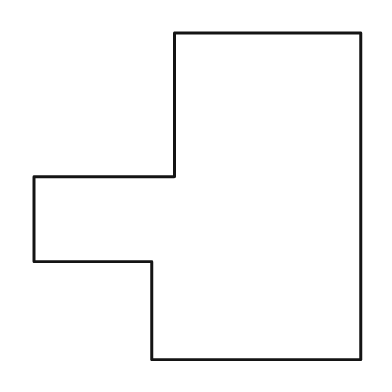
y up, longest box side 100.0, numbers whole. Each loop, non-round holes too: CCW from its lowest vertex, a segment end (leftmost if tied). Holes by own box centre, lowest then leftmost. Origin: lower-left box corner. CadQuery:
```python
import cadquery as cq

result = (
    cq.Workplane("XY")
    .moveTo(36.0, 0.0)
    .lineTo(100.0, 0.0)
    .lineTo(100.0, 100.0)
    .lineTo(43.0, 100.0)
    .lineTo(43.0, 56.0)
    .lineTo(0.0, 56.0)
    .lineTo(0.0, 30.0)
    .lineTo(36.0, 30.0)
    .close()
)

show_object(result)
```